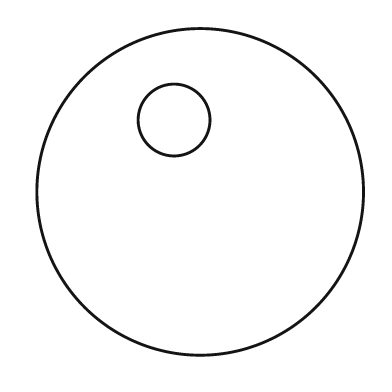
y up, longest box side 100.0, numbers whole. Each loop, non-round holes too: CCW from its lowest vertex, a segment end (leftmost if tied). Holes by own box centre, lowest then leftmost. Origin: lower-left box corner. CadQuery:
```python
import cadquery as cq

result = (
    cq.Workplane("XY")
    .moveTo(50.0, 50.0)
    .circle(50.0)
    .moveTo(42.0, 72.0)
    .circle(11.0)
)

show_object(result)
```